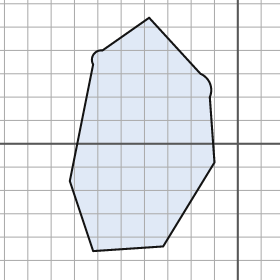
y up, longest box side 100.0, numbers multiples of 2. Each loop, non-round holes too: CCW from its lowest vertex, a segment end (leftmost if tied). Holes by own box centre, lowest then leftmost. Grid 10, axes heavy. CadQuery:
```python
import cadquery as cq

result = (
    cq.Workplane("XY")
    .moveTo(-62.0, -46.0)
    .lineTo(-32.0, -44.0)
    .lineTo(-10.0, -8.0)
    .lineTo(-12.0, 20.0)
    .threePointArc((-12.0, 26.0), (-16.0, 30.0))
    .lineTo(-38.0, 54.0)
    .lineTo(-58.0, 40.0)
    .threePointArc((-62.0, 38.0), (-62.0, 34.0))
    .lineTo(-72.0, -16.0)
    .close()
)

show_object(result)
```